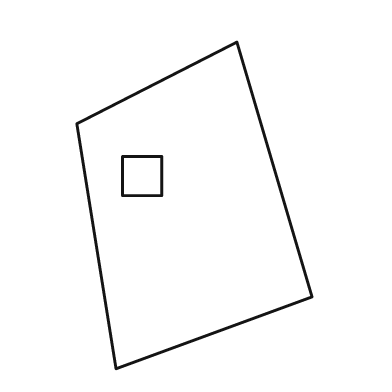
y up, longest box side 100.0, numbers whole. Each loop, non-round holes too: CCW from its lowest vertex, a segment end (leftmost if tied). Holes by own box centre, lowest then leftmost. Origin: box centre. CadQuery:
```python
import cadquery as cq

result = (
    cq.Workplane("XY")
    .moveTo(-24.0, -50.0)
    .lineTo(36.0, -28.0)
    .lineTo(13.0, 50.0)
    .lineTo(-36.0, 25.0)
    .close()
    .moveTo(-22.0, 3.0)
    .lineTo(-10.0, 3.0)
    .lineTo(-10.0, 15.0)
    .lineTo(-22.0, 15.0)
    .close()
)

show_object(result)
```